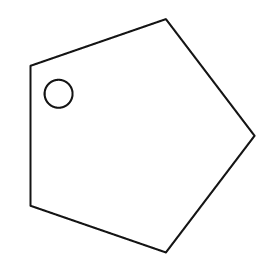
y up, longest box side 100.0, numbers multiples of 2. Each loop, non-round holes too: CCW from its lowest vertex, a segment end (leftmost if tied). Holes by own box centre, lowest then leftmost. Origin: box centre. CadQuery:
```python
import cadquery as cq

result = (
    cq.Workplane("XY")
    .moveTo(10.0, -50.0)
    .lineTo(48.0, 0.0)
    .lineTo(10.0, 50.0)
    .lineTo(-48.0, 30.0)
    .lineTo(-48.0, -30.0)
    .close()
    .moveTo(-36.0, 18.0)
    .circle(6.0)
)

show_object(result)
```